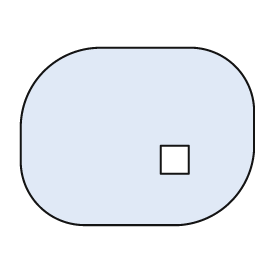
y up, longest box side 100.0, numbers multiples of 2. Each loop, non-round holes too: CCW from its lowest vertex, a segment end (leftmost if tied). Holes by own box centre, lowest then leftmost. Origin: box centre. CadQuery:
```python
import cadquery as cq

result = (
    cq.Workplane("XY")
    .moveTo(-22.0, -38.0)
    .lineTo(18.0, -38.0)
    .threePointArc((40.0, -28.0), (50.0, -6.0))
    .lineTo(50.0, 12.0)
    .threePointArc((42.0, 30.0), (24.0, 38.0))
    .lineTo(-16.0, 38.0)
    .threePointArc((-40.0, 28.0), (-50.0, 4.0))
    .lineTo(-50.0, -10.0)
    .threePointArc((-42.0, -30.0), (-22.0, -38.0))
    .close()
    .moveTo(10.0, -16.0)
    .lineTo(22.0, -16.0)
    .lineTo(22.0, -4.0)
    .lineTo(10.0, -4.0)
    .close()
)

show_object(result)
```